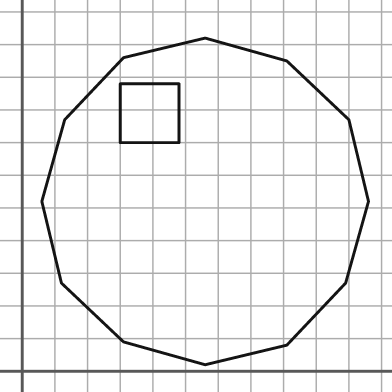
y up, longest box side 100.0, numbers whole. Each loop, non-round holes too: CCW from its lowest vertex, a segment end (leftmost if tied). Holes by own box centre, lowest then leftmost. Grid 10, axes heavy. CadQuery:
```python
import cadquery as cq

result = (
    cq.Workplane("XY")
    .moveTo(56.0, 2.0)
    .lineTo(81.0, 8.0)
    .lineTo(99.0, 27.0)
    .lineTo(106.0, 52.0)
    .lineTo(100.0, 77.0)
    .lineTo(81.0, 95.0)
    .lineTo(56.0, 102.0)
    .lineTo(31.0, 96.0)
    .lineTo(13.0, 77.0)
    .lineTo(6.0, 52.0)
    .lineTo(12.0, 27.0)
    .lineTo(31.0, 9.0)
    .close()
    .moveTo(30.0, 70.0)
    .lineTo(48.0, 70.0)
    .lineTo(48.0, 88.0)
    .lineTo(30.0, 88.0)
    .close()
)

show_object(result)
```